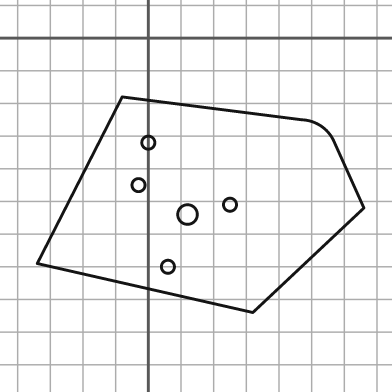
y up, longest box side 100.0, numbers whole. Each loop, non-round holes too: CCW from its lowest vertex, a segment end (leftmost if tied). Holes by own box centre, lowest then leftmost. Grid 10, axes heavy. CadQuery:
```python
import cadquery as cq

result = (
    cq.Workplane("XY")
    .moveTo(32.0, -84.0)
    .lineTo(66.0, -52.0)
    .lineTo(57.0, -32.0)
    .threePointArc((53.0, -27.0), (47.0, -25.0))
    .lineTo(-8.0, -18.0)
    .lineTo(-34.0, -69.0)
    .close()
    .moveTo(6.0, -70.0)
    .circle(2.0)
    .moveTo(12.0, -54.0)
    .circle(3.0)
    .moveTo(25.0, -51.0)
    .circle(2.0)
    .moveTo(-3.0, -45.0)
    .circle(2.0)
    .moveTo(0.0, -32.0)
    .circle(2.0)
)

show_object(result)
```